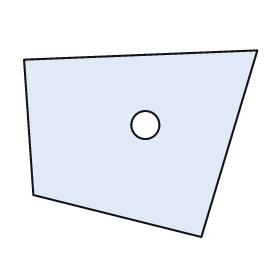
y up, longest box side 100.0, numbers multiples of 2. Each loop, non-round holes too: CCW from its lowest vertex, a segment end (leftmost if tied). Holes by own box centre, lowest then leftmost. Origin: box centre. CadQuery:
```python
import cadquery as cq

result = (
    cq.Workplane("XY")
    .moveTo(26.0, -40.0)
    .lineTo(50.0, 40.0)
    .lineTo(-50.0, 36.0)
    .lineTo(-46.0, -22.0)
    .close()
    .moveTo(2.0, 8.0)
    .circle(6.0)
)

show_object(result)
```